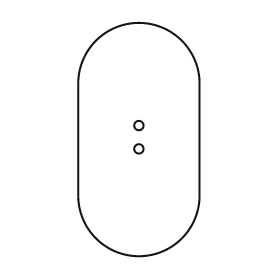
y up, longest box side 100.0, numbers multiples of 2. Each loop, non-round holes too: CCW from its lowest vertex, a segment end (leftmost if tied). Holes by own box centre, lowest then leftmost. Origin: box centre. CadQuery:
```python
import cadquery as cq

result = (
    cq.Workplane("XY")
    .moveTo(-26.0, -24.0)
    .threePointArc((0.0, -50.0), (26.0, -24.0))
    .lineTo(26.0, 24.0)
    .threePointArc((0.0, 50.0), (-26.0, 24.0))
    .close()
    .moveTo(0.0, -4.0)
    .circle(2.0)
    .moveTo(0.0, 6.0)
    .circle(2.0)
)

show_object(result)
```